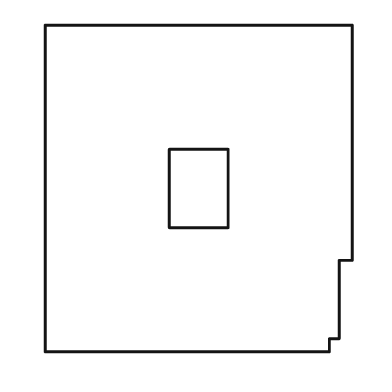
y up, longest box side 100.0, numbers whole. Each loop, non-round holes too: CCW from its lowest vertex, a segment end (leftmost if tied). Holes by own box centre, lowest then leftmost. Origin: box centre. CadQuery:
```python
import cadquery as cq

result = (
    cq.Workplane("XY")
    .moveTo(-47.0, -50.0)
    .lineTo(40.0, -50.0)
    .lineTo(40.0, -46.0)
    .lineTo(43.0, -46.0)
    .lineTo(43.0, -22.0)
    .lineTo(47.0, -22.0)
    .lineTo(47.0, 50.0)
    .lineTo(-47.0, 50.0)
    .close()
    .moveTo(-9.0, -12.0)
    .lineTo(9.0, -12.0)
    .lineTo(9.0, 12.0)
    .lineTo(-9.0, 12.0)
    .close()
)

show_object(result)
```